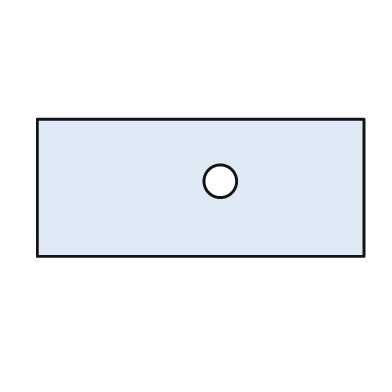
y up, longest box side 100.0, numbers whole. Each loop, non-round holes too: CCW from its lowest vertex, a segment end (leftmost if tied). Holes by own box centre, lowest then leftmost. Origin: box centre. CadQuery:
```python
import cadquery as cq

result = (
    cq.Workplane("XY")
    .moveTo(-50.0, -21.0)
    .lineTo(50.0, -21.0)
    .lineTo(50.0, 21.0)
    .lineTo(-50.0, 21.0)
    .close()
    .moveTo(6.0, 2.0)
    .circle(5.0)
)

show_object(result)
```